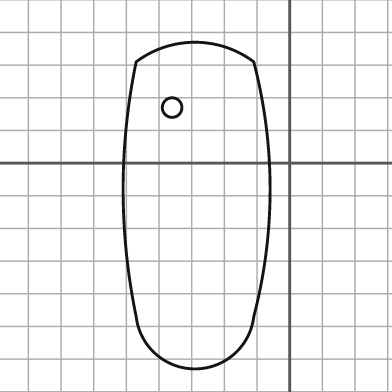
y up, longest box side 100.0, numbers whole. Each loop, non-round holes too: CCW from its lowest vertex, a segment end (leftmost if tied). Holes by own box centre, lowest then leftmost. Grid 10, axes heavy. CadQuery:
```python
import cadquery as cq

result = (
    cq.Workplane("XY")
    .moveTo(-47.0, -47.0)
    .threePointArc((-29.0, -63.0), (-11.0, -47.0))
    .threePointArc((-6.0, -8.0), (-11.0, 31.0))
    .threePointArc((-29.0, 37.0), (-47.0, 31.0))
    .threePointArc((-51.0, -8.0), (-47.0, -47.0))
    .close()
    .moveTo(-36.0, 17.0)
    .circle(3.0)
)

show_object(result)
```